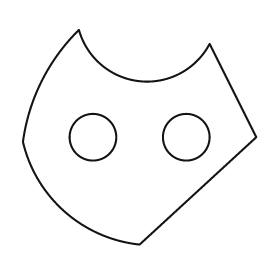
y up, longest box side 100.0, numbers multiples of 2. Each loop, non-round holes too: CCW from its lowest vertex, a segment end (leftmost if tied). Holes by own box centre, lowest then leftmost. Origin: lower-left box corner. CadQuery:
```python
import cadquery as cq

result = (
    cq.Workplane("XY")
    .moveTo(50.0, 0.0)
    .lineTo(100.0, 46.0)
    .lineTo(80.0, 86.0)
    .threePointArc((50.0, 70.0), (24.0, 92.0))
    .threePointArc((8.0, 70.0), (0.0, 44.0))
    .threePointArc((18.0, 14.0), (50.0, 0.0))
    .close()
    .moveTo(30.0, 46.0)
    .circle(10.0)
    .moveTo(70.0, 46.0)
    .circle(10.0)
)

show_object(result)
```